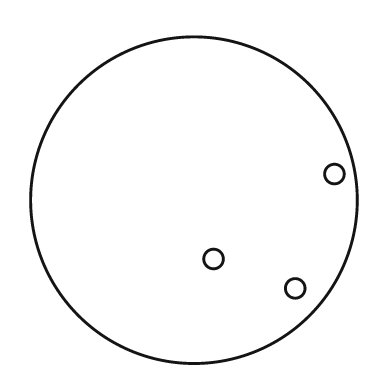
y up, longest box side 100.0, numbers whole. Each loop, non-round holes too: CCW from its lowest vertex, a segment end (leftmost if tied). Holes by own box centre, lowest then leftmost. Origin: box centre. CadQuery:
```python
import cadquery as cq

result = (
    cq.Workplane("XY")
    .moveTo(0.0, 0.0)
    .circle(50.0)
    .moveTo(31.0, -27.0)
    .circle(3.0)
    .moveTo(6.0, -18.0)
    .circle(3.0)
    .moveTo(43.0, 8.0)
    .circle(3.0)
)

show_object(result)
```